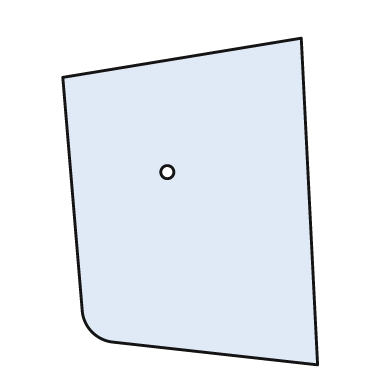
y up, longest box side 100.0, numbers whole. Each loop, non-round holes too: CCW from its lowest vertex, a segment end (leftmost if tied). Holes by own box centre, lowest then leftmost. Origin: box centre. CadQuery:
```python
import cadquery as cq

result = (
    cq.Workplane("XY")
    .moveTo(39.0, -50.0)
    .lineTo(34.0, 50.0)
    .lineTo(-39.0, 38.0)
    .lineTo(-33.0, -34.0)
    .threePointArc((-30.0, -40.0), (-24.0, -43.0))
    .close()
    .moveTo(-7.0, 9.0)
    .circle(2.0)
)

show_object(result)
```